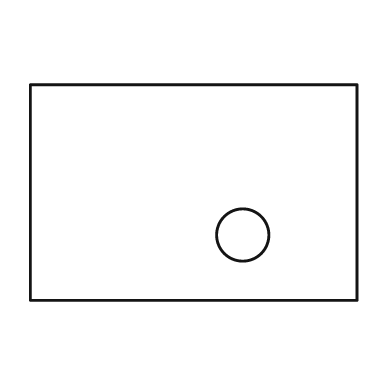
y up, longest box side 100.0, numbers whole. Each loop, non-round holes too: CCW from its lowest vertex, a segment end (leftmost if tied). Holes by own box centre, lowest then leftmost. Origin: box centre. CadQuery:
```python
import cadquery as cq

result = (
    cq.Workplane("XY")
    .moveTo(-50.0, -33.0)
    .lineTo(50.0, -33.0)
    .lineTo(50.0, 33.0)
    .lineTo(-50.0, 33.0)
    .close()
    .moveTo(15.0, -13.0)
    .circle(8.0)
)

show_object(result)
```